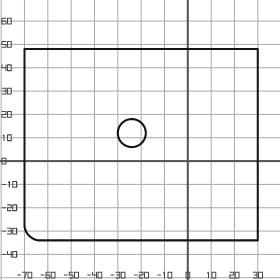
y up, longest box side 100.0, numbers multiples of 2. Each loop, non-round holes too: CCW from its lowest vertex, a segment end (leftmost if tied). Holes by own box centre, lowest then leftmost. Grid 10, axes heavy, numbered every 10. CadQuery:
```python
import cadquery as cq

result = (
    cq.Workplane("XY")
    .moveTo(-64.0, -34.0)
    .lineTo(30.0, -34.0)
    .lineTo(30.0, 48.0)
    .lineTo(-70.0, 48.0)
    .lineTo(-70.0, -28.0)
    .threePointArc((-68.0, -32.0), (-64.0, -34.0))
    .close()
    .moveTo(-24.0, 12.0)
    .circle(6.0)
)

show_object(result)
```